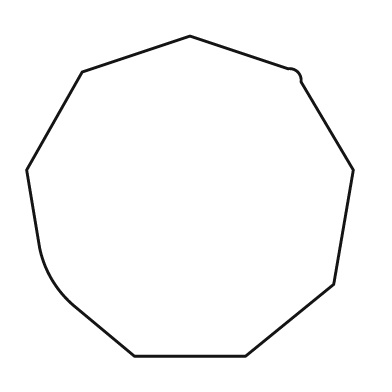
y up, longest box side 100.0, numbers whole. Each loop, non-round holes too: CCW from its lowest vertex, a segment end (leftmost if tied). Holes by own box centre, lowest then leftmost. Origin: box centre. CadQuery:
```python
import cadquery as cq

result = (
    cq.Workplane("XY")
    .moveTo(-17.0, -49.0)
    .lineTo(17.0, -49.0)
    .lineTo(44.0, -27.0)
    .lineTo(50.0, 8.0)
    .lineTo(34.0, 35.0)
    .threePointArc((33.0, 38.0), (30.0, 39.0))
    .lineTo(0.0, 49.0)
    .lineTo(-33.0, 38.0)
    .lineTo(-50.0, 8.0)
    .lineTo(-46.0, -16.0)
    .threePointArc((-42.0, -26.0), (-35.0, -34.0))
    .close()
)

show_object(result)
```